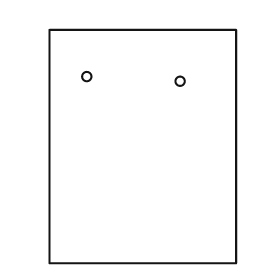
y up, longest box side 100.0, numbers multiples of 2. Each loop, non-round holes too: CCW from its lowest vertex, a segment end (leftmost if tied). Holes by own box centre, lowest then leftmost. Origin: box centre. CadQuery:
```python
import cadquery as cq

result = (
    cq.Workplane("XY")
    .moveTo(-40.0, -50.0)
    .lineTo(40.0, -50.0)
    .lineTo(40.0, 50.0)
    .lineTo(-40.0, 50.0)
    .close()
    .moveTo(16.0, 28.0)
    .circle(2.0)
    .moveTo(-24.0, 30.0)
    .circle(2.0)
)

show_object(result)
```